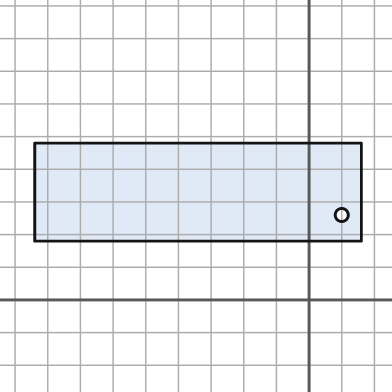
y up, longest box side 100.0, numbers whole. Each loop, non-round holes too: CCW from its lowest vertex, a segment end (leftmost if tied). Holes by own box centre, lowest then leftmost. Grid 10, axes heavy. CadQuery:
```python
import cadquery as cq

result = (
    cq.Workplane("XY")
    .moveTo(-84.0, 18.0)
    .lineTo(16.0, 18.0)
    .lineTo(16.0, 48.0)
    .lineTo(-84.0, 48.0)
    .close()
    .moveTo(10.0, 26.0)
    .circle(2.0)
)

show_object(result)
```